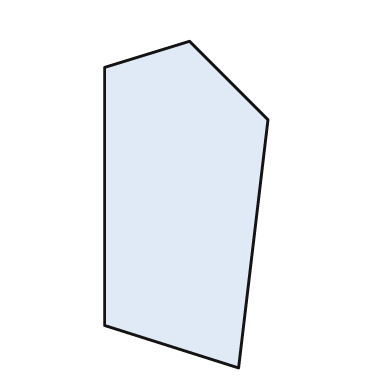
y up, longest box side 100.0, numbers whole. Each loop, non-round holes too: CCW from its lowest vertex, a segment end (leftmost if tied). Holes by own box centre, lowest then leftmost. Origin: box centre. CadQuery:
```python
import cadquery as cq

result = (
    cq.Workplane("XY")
    .moveTo(16.0, -50.0)
    .lineTo(25.0, 26.0)
    .lineTo(1.0, 50.0)
    .lineTo(-25.0, 42.0)
    .lineTo(-25.0, -37.0)
    .close()
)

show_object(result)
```